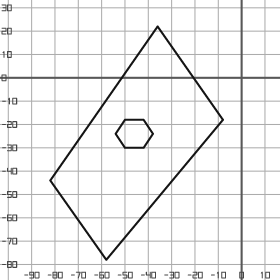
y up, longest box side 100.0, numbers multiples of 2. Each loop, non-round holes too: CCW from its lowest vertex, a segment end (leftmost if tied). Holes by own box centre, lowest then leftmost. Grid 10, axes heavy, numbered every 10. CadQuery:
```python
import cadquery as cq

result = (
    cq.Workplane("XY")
    .moveTo(-58.0, -78.0)
    .lineTo(-8.0, -18.0)
    .lineTo(-36.0, 22.0)
    .lineTo(-82.0, -44.0)
    .close()
    .moveTo(-50.0, -30.0)
    .lineTo(-42.0, -30.0)
    .lineTo(-38.0, -24.0)
    .lineTo(-42.0, -18.0)
    .lineTo(-50.0, -18.0)
    .lineTo(-54.0, -24.0)
    .close()
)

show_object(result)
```